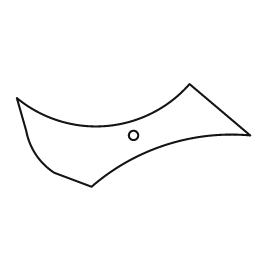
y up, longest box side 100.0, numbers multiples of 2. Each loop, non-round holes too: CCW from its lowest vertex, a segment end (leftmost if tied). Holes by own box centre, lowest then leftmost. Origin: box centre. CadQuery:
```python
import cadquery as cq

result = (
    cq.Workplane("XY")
    .moveTo(-18.0, -22.0)
    .threePointArc((14.0, -4.0), (50.0, 0.0))
    .lineTo(24.0, 22.0)
    .threePointArc((-12.0, 4.0), (-50.0, 16.0))
    .lineTo(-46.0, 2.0)
    .threePointArc((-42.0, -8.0), (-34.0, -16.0))
    .close()
    .moveTo(0.0, 0.0)
    .circle(2.0)
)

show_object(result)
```